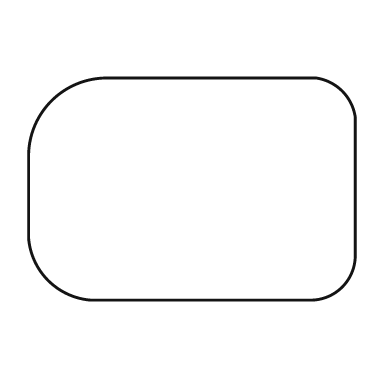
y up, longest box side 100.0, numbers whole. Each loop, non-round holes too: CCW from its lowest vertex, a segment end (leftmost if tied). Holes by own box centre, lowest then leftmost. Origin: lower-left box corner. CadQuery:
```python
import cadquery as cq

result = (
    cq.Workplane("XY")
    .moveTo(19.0, 0.0)
    .lineTo(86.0, 0.0)
    .threePointArc((96.0, 4.0), (100.0, 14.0))
    .lineTo(100.0, 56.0)
    .threePointArc((96.0, 64.0), (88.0, 68.0))
    .lineTo(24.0, 68.0)
    .threePointArc((7.0, 61.0), (0.0, 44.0))
    .lineTo(0.0, 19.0)
    .threePointArc((6.0, 6.0), (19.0, 0.0))
    .close()
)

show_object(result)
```